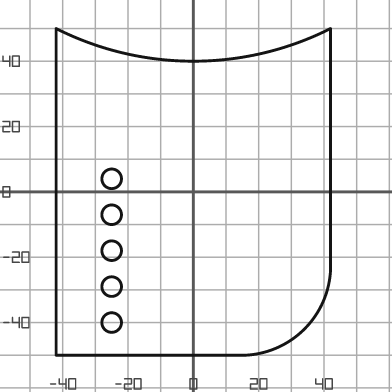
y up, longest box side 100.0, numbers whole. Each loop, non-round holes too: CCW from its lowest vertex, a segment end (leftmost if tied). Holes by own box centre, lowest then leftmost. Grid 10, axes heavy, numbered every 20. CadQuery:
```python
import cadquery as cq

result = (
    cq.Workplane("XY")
    .moveTo(-42.0, -50.0)
    .lineTo(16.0, -50.0)
    .threePointArc((34.0, -42.0), (42.0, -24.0))
    .lineTo(42.0, 50.0)
    .threePointArc((0.0, 40.0), (-42.0, 50.0))
    .close()
    .moveTo(-25.0, -40.0)
    .circle(3.0)
    .moveTo(-25.0, -29.0)
    .circle(3.0)
    .moveTo(-25.0, -18.0)
    .circle(3.0)
    .moveTo(-25.0, -7.0)
    .circle(3.0)
    .moveTo(-25.0, 4.0)
    .circle(3.0)
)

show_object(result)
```